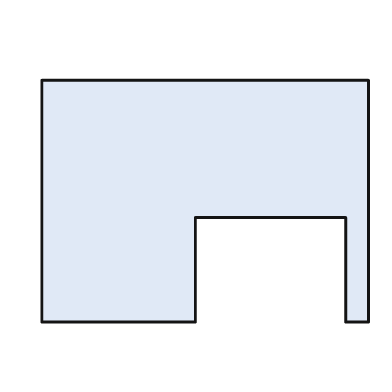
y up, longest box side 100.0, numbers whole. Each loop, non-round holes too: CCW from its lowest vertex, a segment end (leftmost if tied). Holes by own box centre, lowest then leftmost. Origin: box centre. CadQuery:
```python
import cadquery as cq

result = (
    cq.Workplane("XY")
    .moveTo(-50.0, -37.0)
    .lineTo(-3.0, -37.0)
    .lineTo(-3.0, -5.0)
    .lineTo(43.0, -5.0)
    .lineTo(43.0, -37.0)
    .lineTo(50.0, -37.0)
    .lineTo(50.0, 37.0)
    .lineTo(-50.0, 37.0)
    .close()
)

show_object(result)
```